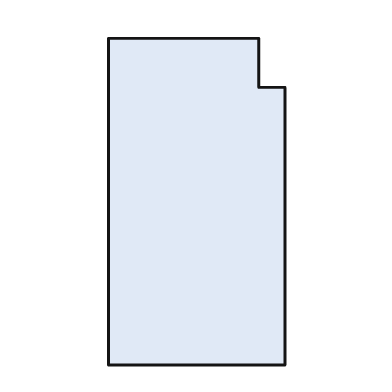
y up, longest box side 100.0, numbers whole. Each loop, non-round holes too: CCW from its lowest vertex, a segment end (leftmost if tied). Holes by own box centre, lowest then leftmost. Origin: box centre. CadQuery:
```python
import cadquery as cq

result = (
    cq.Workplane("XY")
    .moveTo(-27.0, -50.0)
    .lineTo(27.0, -50.0)
    .lineTo(27.0, 35.0)
    .lineTo(19.0, 35.0)
    .lineTo(19.0, 50.0)
    .lineTo(-27.0, 50.0)
    .close()
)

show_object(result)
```